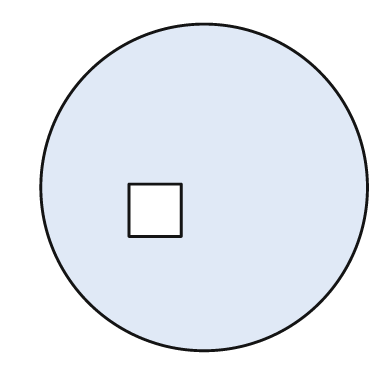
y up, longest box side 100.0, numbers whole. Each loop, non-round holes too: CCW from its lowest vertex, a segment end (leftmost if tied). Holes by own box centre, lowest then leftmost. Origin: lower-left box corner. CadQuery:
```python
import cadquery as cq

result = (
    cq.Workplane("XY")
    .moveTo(50.0, 50.0)
    .circle(50.0)
    .moveTo(27.0, 35.0)
    .lineTo(43.0, 35.0)
    .lineTo(43.0, 51.0)
    .lineTo(27.0, 51.0)
    .close()
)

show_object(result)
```